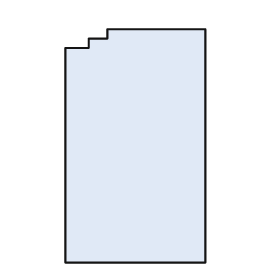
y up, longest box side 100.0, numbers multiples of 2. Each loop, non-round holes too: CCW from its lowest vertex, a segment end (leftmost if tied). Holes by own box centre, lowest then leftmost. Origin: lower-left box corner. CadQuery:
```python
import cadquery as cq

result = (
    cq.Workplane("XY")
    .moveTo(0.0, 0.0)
    .lineTo(60.0, 0.0)
    .lineTo(60.0, 100.0)
    .lineTo(18.0, 100.0)
    .lineTo(18.0, 96.0)
    .lineTo(10.0, 96.0)
    .lineTo(10.0, 92.0)
    .lineTo(0.0, 92.0)
    .close()
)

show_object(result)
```